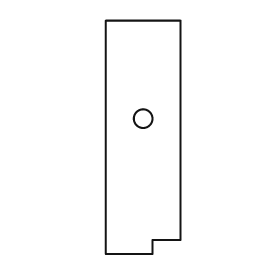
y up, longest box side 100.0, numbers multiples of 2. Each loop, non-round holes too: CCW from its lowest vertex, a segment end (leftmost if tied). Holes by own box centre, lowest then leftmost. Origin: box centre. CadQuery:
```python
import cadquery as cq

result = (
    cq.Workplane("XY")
    .moveTo(-16.0, -50.0)
    .lineTo(4.0, -50.0)
    .lineTo(4.0, -44.0)
    .lineTo(16.0, -44.0)
    .lineTo(16.0, 50.0)
    .lineTo(-16.0, 50.0)
    .close()
    .moveTo(0.0, 8.0)
    .circle(4.0)
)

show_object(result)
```